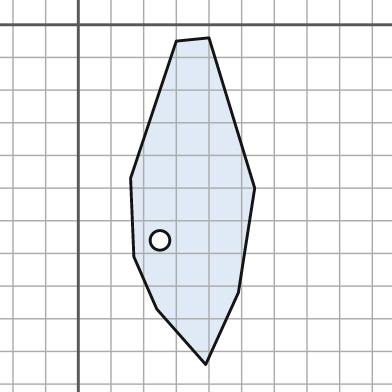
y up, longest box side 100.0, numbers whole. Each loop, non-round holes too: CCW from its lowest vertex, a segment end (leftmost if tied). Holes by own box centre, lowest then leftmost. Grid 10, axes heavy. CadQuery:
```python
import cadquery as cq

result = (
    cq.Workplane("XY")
    .moveTo(39.0, -104.0)
    .lineTo(49.0, -82.0)
    .lineTo(54.0, -50.0)
    .lineTo(40.0, -4.0)
    .lineTo(30.0, -5.0)
    .lineTo(16.0, -47.0)
    .lineTo(17.0, -71.0)
    .lineTo(24.0, -87.0)
    .close()
    .moveTo(25.0, -66.0)
    .circle(3.0)
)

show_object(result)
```